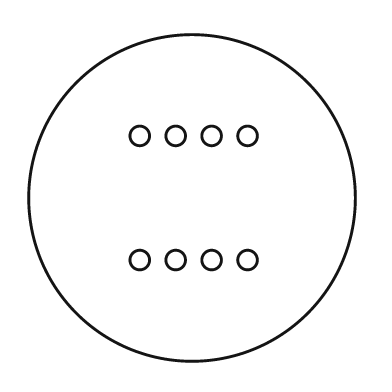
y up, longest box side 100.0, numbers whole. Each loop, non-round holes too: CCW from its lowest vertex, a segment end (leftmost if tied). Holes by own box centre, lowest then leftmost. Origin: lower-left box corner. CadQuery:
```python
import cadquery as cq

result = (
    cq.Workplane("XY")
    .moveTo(50.0, 50.0)
    .circle(50.0)
    .moveTo(34.0, 31.0)
    .circle(3.0)
    .moveTo(45.0, 31.0)
    .circle(3.0)
    .moveTo(56.0, 31.0)
    .circle(3.0)
    .moveTo(67.0, 31.0)
    .circle(3.0)
    .moveTo(34.0, 69.0)
    .circle(3.0)
    .moveTo(45.0, 69.0)
    .circle(3.0)
    .moveTo(56.0, 69.0)
    .circle(3.0)
    .moveTo(67.0, 69.0)
    .circle(3.0)
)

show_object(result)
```